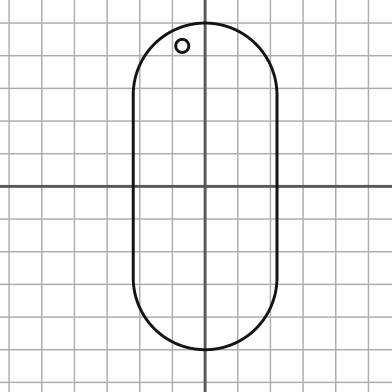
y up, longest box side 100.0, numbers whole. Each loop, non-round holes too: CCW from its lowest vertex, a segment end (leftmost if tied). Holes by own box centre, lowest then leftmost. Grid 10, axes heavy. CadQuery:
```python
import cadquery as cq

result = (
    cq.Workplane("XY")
    .moveTo(-22.0, -28.0)
    .threePointArc((0.0, -50.0), (22.0, -28.0))
    .lineTo(22.0, 28.0)
    .threePointArc((0.0, 50.0), (-22.0, 28.0))
    .close()
    .moveTo(-7.0, 43.0)
    .circle(2.0)
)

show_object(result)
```